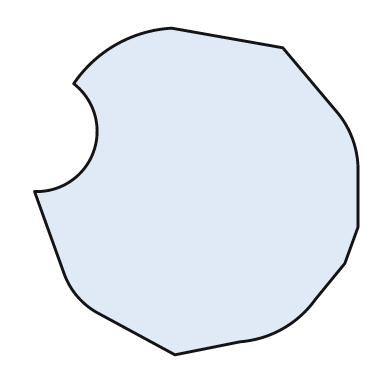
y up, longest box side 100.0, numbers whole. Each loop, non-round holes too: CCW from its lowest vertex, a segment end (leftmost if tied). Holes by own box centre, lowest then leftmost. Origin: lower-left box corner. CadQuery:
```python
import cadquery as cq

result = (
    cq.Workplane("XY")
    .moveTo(43.0, 0.0)
    .lineTo(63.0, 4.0)
    .threePointArc((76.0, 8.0), (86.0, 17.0))
    .lineTo(95.0, 28.0)
    .lineTo(99.0, 39.0)
    .lineTo(99.0, 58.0)
    .threePointArc((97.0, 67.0), (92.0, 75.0))
    .lineTo(76.0, 94.0)
    .lineTo(42.0, 100.0)
    .threePointArc((25.0, 95.0), (12.0, 83.0))
    .threePointArc((18.0, 62.0), (0.0, 50.0))
    .lineTo(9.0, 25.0)
    .threePointArc((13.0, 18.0), (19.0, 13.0))
    .close()
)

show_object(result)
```